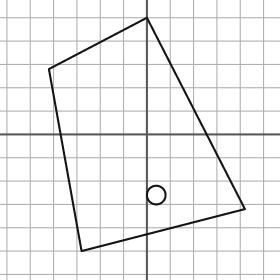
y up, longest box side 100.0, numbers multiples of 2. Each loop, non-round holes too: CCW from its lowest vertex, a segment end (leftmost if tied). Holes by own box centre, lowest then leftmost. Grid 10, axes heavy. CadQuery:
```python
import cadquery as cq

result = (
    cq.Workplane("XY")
    .moveTo(-28.0, -50.0)
    .lineTo(42.0, -32.0)
    .lineTo(0.0, 50.0)
    .lineTo(-42.0, 28.0)
    .close()
    .moveTo(4.0, -26.0)
    .circle(4.0)
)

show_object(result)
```